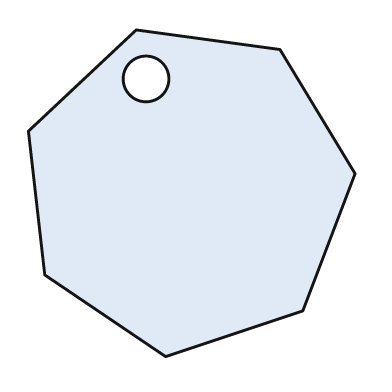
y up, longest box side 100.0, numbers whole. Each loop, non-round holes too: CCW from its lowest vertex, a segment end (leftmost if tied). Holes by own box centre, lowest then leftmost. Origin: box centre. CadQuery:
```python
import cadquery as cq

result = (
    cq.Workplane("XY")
    .moveTo(-8.0, -50.0)
    .lineTo(34.0, -36.0)
    .lineTo(50.0, 6.0)
    .lineTo(27.0, 44.0)
    .lineTo(-17.0, 50.0)
    .lineTo(-50.0, 19.0)
    .lineTo(-45.0, -25.0)
    .close()
    .moveTo(-14.0, 35.0)
    .circle(7.0)
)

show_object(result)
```